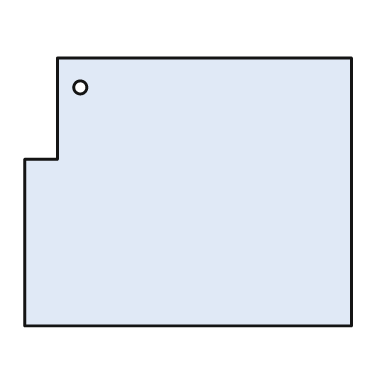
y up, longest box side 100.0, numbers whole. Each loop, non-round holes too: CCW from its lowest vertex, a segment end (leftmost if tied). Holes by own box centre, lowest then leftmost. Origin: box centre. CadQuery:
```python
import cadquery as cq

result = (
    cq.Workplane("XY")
    .moveTo(-50.0, -41.0)
    .lineTo(50.0, -41.0)
    .lineTo(50.0, 41.0)
    .lineTo(-40.0, 41.0)
    .lineTo(-40.0, 10.0)
    .lineTo(-50.0, 10.0)
    .close()
    .moveTo(-33.0, 32.0)
    .circle(2.0)
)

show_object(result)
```